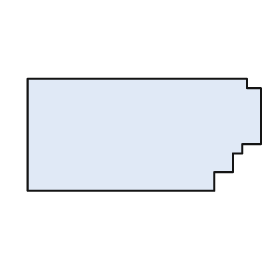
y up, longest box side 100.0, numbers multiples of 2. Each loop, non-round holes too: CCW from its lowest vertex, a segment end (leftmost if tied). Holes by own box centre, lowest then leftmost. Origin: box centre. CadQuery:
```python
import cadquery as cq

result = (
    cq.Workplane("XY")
    .moveTo(-50.0, -24.0)
    .lineTo(30.0, -24.0)
    .lineTo(30.0, -16.0)
    .lineTo(38.0, -16.0)
    .lineTo(38.0, -8.0)
    .lineTo(42.0, -8.0)
    .lineTo(42.0, -4.0)
    .lineTo(50.0, -4.0)
    .lineTo(50.0, 20.0)
    .lineTo(44.0, 20.0)
    .lineTo(44.0, 24.0)
    .lineTo(-50.0, 24.0)
    .close()
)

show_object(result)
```